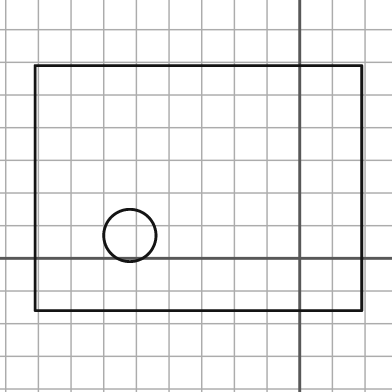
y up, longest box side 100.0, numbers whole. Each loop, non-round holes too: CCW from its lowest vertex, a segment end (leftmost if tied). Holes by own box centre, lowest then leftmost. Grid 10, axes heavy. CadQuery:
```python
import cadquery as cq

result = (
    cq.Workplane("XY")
    .moveTo(-81.0, -16.0)
    .lineTo(19.0, -16.0)
    .lineTo(19.0, 59.0)
    .lineTo(-81.0, 59.0)
    .close()
    .moveTo(-52.0, 7.0)
    .circle(8.0)
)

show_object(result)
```